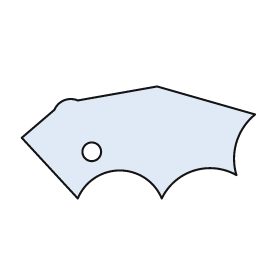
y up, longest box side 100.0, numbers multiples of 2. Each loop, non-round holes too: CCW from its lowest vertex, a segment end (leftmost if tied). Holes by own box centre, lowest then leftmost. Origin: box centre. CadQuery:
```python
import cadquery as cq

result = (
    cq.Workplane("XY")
    .moveTo(-26.0, -24.0)
    .threePointArc((-8.0, -12.0), (10.0, -24.0))
    .threePointArc((24.0, -12.0), (42.0, -14.0))
    .threePointArc((42.0, 0.0), (50.0, 12.0))
    .lineTo(8.0, 24.0)
    .lineTo(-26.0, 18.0)
    .threePointArc((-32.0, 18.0), (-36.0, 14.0))
    .lineTo(-50.0, 2.0)
    .close()
    .moveTo(-20.0, -4.0)
    .circle(4.0)
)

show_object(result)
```